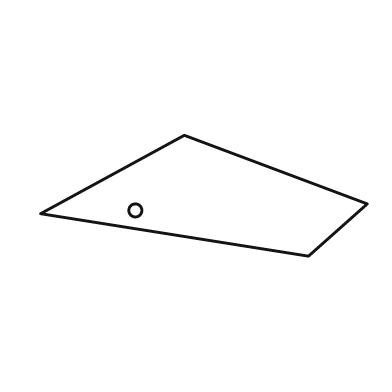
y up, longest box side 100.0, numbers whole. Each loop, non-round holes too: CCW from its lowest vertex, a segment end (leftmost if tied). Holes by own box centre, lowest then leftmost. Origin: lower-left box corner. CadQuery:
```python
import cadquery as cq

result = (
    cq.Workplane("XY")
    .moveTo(82.0, 0.0)
    .lineTo(100.0, 16.0)
    .lineTo(44.0, 37.0)
    .lineTo(0.0, 13.0)
    .close()
    .moveTo(29.0, 14.0)
    .circle(2.0)
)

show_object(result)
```